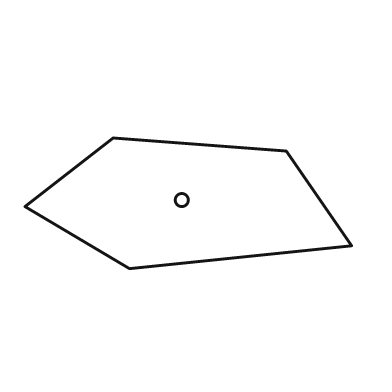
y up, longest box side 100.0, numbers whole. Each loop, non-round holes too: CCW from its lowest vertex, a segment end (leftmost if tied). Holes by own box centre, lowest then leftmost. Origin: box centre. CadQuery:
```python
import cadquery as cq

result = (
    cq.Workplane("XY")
    .moveTo(-18.0, -20.0)
    .lineTo(50.0, -13.0)
    .lineTo(30.0, 16.0)
    .lineTo(-23.0, 20.0)
    .lineTo(-50.0, -1.0)
    .close()
    .moveTo(-2.0, 1.0)
    .circle(2.0)
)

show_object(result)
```